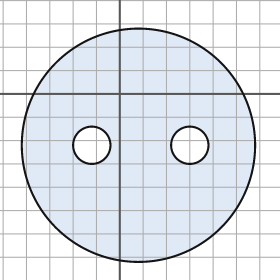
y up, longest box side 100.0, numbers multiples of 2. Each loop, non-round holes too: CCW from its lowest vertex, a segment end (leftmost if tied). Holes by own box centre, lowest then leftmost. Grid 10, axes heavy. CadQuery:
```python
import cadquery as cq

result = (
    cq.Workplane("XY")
    .moveTo(8.0, -22.0)
    .circle(50.0)
    .moveTo(-12.0, -22.0)
    .circle(8.0)
    .moveTo(30.0, -22.0)
    .circle(8.0)
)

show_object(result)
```